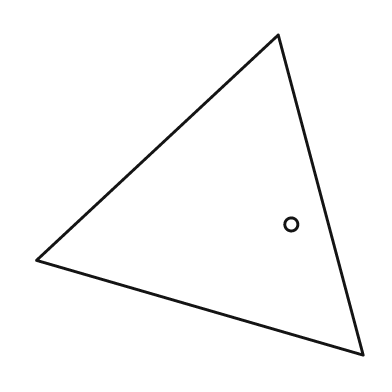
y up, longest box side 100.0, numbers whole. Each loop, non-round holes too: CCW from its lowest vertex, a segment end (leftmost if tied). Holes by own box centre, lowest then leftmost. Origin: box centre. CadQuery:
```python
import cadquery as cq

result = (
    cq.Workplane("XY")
    .moveTo(50.0, -49.0)
    .lineTo(24.0, 49.0)
    .lineTo(-50.0, -20.0)
    .close()
    .moveTo(28.0, -9.0)
    .circle(2.0)
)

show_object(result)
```